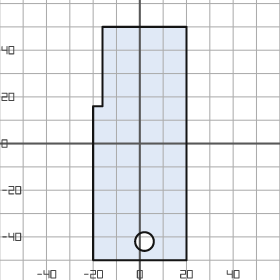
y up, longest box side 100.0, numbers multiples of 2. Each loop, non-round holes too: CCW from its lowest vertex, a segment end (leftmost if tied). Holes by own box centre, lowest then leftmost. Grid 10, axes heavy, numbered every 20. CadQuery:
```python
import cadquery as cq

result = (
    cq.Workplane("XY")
    .moveTo(-20.0, -50.0)
    .lineTo(20.0, -50.0)
    .lineTo(20.0, 50.0)
    .lineTo(-16.0, 50.0)
    .lineTo(-16.0, 16.0)
    .lineTo(-20.0, 16.0)
    .close()
    .moveTo(2.0, -42.0)
    .circle(4.0)
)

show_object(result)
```